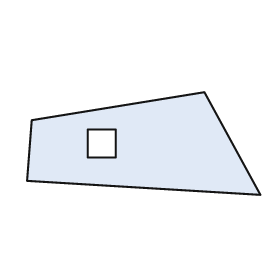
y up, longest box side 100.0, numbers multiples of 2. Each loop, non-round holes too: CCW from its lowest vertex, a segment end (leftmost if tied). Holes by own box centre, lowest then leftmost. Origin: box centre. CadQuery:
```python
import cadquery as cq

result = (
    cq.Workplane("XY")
    .moveTo(50.0, -22.0)
    .lineTo(26.0, 22.0)
    .lineTo(-48.0, 10.0)
    .lineTo(-50.0, -16.0)
    .close()
    .moveTo(-24.0, -6.0)
    .lineTo(-12.0, -6.0)
    .lineTo(-12.0, 6.0)
    .lineTo(-24.0, 6.0)
    .close()
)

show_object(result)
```